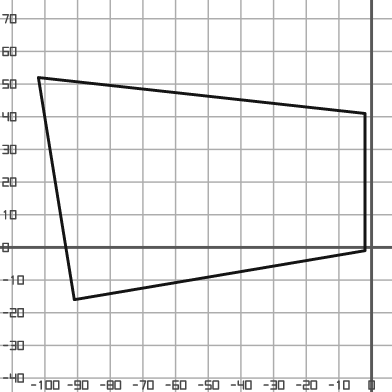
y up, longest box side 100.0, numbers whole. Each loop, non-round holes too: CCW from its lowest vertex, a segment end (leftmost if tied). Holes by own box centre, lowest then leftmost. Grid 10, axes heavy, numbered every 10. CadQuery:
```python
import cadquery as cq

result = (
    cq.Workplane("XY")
    .moveTo(-91.0, -16.0)
    .lineTo(-2.0, -1.0)
    .lineTo(-2.0, 41.0)
    .lineTo(-102.0, 52.0)
    .close()
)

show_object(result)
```